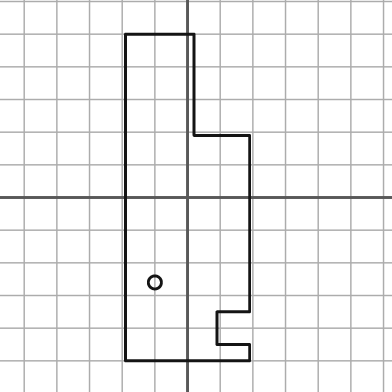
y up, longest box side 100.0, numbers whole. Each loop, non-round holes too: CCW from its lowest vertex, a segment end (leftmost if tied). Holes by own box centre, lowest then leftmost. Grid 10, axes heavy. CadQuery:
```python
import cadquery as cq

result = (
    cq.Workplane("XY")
    .moveTo(-19.0, -50.0)
    .lineTo(19.0, -50.0)
    .lineTo(19.0, -45.0)
    .lineTo(9.0, -45.0)
    .lineTo(9.0, -35.0)
    .lineTo(19.0, -35.0)
    .lineTo(19.0, 19.0)
    .lineTo(2.0, 19.0)
    .lineTo(2.0, 50.0)
    .lineTo(-19.0, 50.0)
    .close()
    .moveTo(-10.0, -26.0)
    .circle(2.0)
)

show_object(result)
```